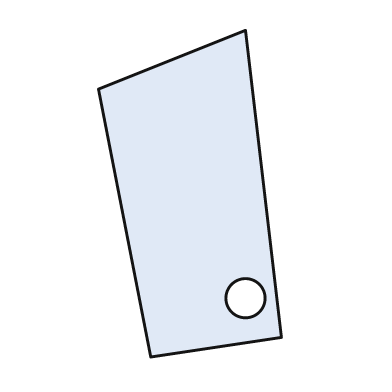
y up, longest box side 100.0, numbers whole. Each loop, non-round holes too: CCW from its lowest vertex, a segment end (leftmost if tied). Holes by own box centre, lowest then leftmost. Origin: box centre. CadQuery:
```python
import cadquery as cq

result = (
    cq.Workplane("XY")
    .moveTo(-12.0, -50.0)
    .lineTo(28.0, -44.0)
    .lineTo(17.0, 50.0)
    .lineTo(-28.0, 32.0)
    .close()
    .moveTo(17.0, -32.0)
    .circle(6.0)
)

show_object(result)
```